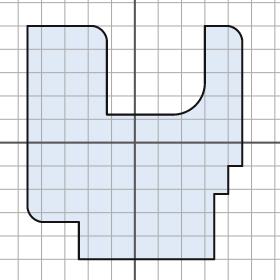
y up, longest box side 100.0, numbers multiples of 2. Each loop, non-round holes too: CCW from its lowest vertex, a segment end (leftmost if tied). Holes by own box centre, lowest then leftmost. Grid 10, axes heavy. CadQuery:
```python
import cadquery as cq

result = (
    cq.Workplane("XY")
    .moveTo(-24.0, -50.0)
    .lineTo(34.0, -50.0)
    .lineTo(34.0, -22.0)
    .lineTo(40.0, -22.0)
    .lineTo(40.0, -10.0)
    .lineTo(46.0, -10.0)
    .lineTo(46.0, 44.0)
    .threePointArc((44.0, 48.0), (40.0, 50.0))
    .lineTo(30.0, 50.0)
    .lineTo(30.0, 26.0)
    .threePointArc((26.0, 16.0), (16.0, 12.0))
    .lineTo(-12.0, 12.0)
    .lineTo(-12.0, 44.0)
    .threePointArc((-14.0, 48.0), (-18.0, 50.0))
    .lineTo(-46.0, 50.0)
    .lineTo(-46.0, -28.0)
    .threePointArc((-44.0, -32.0), (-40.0, -34.0))
    .lineTo(-24.0, -34.0)
    .close()
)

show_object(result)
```